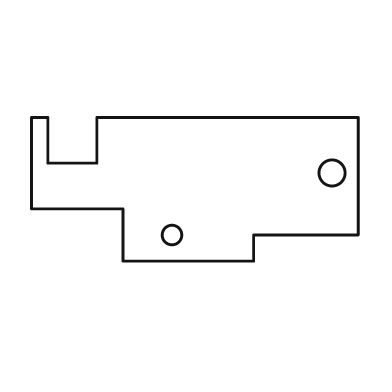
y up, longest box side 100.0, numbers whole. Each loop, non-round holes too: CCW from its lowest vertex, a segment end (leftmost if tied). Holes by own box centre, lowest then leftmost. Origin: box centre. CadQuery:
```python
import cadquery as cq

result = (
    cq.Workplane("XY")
    .moveTo(-22.0, -22.0)
    .lineTo(18.0, -22.0)
    .lineTo(18.0, -14.0)
    .lineTo(50.0, -14.0)
    .lineTo(50.0, 22.0)
    .lineTo(-30.0, 22.0)
    .lineTo(-30.0, 8.0)
    .lineTo(-45.0, 8.0)
    .lineTo(-45.0, 22.0)
    .lineTo(-50.0, 22.0)
    .lineTo(-50.0, -6.0)
    .lineTo(-22.0, -6.0)
    .close()
    .moveTo(-7.0, -14.0)
    .circle(3.0)
    .moveTo(42.0, 5.0)
    .circle(4.0)
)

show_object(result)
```